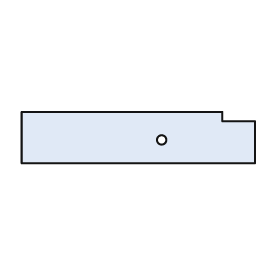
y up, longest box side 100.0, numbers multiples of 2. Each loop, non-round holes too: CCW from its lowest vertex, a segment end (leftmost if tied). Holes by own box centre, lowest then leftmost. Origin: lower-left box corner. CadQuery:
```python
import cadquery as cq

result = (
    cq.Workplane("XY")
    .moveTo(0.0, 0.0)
    .lineTo(100.0, 0.0)
    .lineTo(100.0, 18.0)
    .lineTo(86.0, 18.0)
    .lineTo(86.0, 22.0)
    .lineTo(0.0, 22.0)
    .close()
    .moveTo(60.0, 10.0)
    .circle(2.0)
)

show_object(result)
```